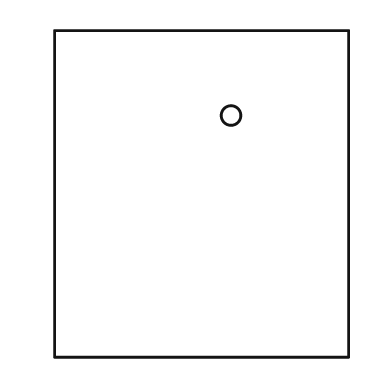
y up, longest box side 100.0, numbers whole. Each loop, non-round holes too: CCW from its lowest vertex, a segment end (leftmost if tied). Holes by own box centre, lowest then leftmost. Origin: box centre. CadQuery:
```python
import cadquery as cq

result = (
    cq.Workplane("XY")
    .moveTo(-45.0, -50.0)
    .lineTo(45.0, -50.0)
    .lineTo(45.0, 50.0)
    .lineTo(-45.0, 50.0)
    .close()
    .moveTo(9.0, 24.0)
    .circle(3.0)
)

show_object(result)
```